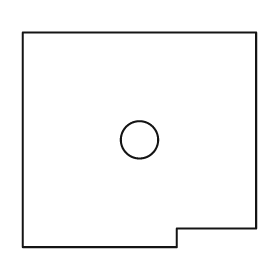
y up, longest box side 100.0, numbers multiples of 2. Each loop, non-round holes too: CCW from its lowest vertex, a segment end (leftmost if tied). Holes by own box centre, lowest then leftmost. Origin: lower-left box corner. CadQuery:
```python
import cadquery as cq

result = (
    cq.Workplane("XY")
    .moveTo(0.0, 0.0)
    .lineTo(66.0, 0.0)
    .lineTo(66.0, 8.0)
    .lineTo(100.0, 8.0)
    .lineTo(100.0, 92.0)
    .lineTo(0.0, 92.0)
    .close()
    .moveTo(50.0, 46.0)
    .circle(8.0)
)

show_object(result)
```